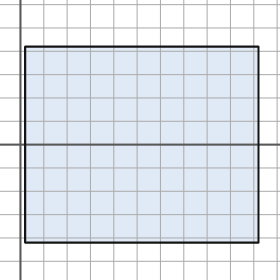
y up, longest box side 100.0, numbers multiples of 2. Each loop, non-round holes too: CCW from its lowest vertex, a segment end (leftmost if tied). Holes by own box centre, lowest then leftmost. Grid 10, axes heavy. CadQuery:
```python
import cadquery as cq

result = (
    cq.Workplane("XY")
    .moveTo(2.0, -42.0)
    .lineTo(102.0, -42.0)
    .lineTo(102.0, 42.0)
    .lineTo(2.0, 42.0)
    .close()
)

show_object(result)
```